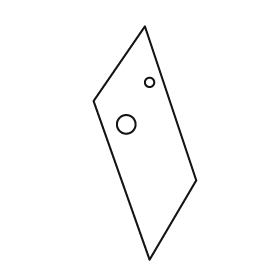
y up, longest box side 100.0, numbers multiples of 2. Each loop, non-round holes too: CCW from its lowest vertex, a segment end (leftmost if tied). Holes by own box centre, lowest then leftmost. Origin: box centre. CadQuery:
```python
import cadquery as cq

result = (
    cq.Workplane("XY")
    .moveTo(2.0, -50.0)
    .lineTo(22.0, -16.0)
    .lineTo(0.0, 50.0)
    .lineTo(-22.0, 18.0)
    .close()
    .moveTo(-8.0, 8.0)
    .circle(4.0)
    .moveTo(2.0, 26.0)
    .circle(2.0)
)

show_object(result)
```